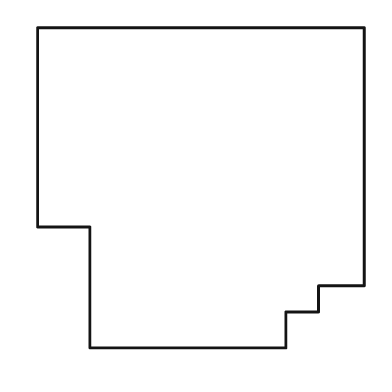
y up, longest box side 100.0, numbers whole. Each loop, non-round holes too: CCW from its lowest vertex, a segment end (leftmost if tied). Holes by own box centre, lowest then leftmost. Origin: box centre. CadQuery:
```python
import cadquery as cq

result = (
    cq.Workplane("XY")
    .moveTo(-34.0, -49.0)
    .lineTo(26.0, -49.0)
    .lineTo(26.0, -38.0)
    .lineTo(36.0, -38.0)
    .lineTo(36.0, -30.0)
    .lineTo(50.0, -30.0)
    .lineTo(50.0, 49.0)
    .lineTo(-50.0, 49.0)
    .lineTo(-50.0, -12.0)
    .lineTo(-34.0, -12.0)
    .close()
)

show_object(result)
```